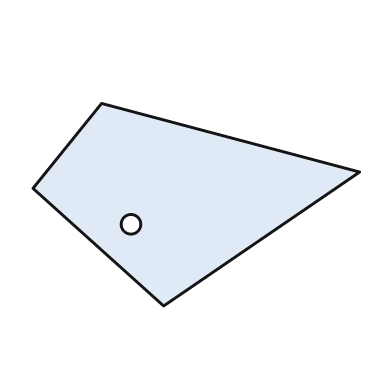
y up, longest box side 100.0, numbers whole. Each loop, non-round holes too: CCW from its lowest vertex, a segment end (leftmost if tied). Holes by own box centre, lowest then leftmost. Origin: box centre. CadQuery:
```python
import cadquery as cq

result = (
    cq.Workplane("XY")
    .moveTo(-10.0, -31.0)
    .lineTo(50.0, 10.0)
    .lineTo(-29.0, 31.0)
    .lineTo(-50.0, 5.0)
    .close()
    .moveTo(-20.0, -6.0)
    .circle(3.0)
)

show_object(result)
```